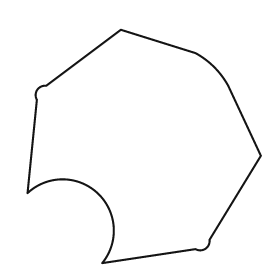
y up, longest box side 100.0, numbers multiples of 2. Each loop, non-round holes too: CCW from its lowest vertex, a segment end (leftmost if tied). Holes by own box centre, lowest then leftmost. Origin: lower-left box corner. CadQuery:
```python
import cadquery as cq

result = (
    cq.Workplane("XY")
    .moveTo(32.0, 0.0)
    .lineTo(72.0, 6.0)
    .threePointArc((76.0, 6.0), (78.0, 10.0))
    .lineTo(100.0, 46.0)
    .lineTo(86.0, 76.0)
    .threePointArc((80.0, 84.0), (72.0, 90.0))
    .lineTo(40.0, 100.0)
    .lineTo(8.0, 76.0)
    .threePointArc((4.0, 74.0), (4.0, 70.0))
    .lineTo(0.0, 30.0)
    .threePointArc((30.0, 30.0), (32.0, 0.0))
    .close()
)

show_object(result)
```